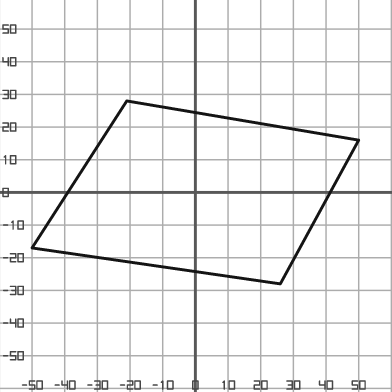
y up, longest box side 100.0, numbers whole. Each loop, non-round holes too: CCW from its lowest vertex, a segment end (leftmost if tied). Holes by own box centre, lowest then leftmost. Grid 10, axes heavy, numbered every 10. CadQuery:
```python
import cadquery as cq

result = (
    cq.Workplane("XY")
    .moveTo(26.0, -28.0)
    .lineTo(50.0, 16.0)
    .lineTo(-21.0, 28.0)
    .lineTo(-50.0, -17.0)
    .close()
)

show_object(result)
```